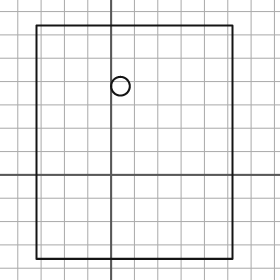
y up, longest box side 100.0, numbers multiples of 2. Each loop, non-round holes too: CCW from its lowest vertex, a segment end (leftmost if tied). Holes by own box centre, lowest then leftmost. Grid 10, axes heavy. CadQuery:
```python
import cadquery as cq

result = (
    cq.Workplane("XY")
    .moveTo(-32.0, -36.0)
    .lineTo(52.0, -36.0)
    .lineTo(52.0, 64.0)
    .lineTo(-32.0, 64.0)
    .close()
    .moveTo(4.0, 38.0)
    .circle(4.0)
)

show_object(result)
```